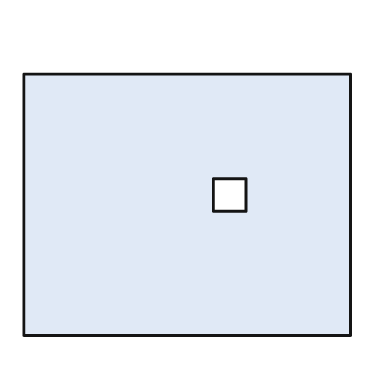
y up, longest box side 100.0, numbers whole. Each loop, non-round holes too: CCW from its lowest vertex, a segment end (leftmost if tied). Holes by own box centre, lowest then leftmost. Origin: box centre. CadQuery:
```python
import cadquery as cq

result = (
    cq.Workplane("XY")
    .moveTo(-50.0, -40.0)
    .lineTo(50.0, -40.0)
    .lineTo(50.0, 40.0)
    .lineTo(-50.0, 40.0)
    .close()
    .moveTo(8.0, -2.0)
    .lineTo(18.0, -2.0)
    .lineTo(18.0, 8.0)
    .lineTo(8.0, 8.0)
    .close()
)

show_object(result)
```